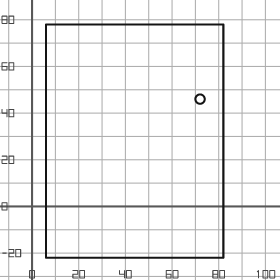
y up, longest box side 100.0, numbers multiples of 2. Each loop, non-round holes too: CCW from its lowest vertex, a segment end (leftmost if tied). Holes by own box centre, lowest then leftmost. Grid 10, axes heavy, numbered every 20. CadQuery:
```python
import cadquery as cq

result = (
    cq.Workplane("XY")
    .moveTo(6.0, -22.0)
    .lineTo(82.0, -22.0)
    .lineTo(82.0, 78.0)
    .lineTo(6.0, 78.0)
    .close()
    .moveTo(72.0, 46.0)
    .circle(2.0)
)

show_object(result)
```